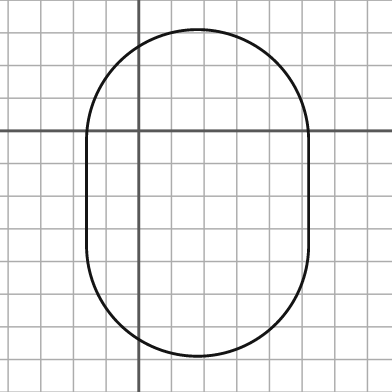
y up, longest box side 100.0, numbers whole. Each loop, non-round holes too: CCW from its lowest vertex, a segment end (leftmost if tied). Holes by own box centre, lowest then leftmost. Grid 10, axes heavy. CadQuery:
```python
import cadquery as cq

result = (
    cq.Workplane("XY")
    .moveTo(-16.0, -35.0)
    .threePointArc((18.0, -69.0), (52.0, -35.0))
    .lineTo(52.0, -3.0)
    .threePointArc((18.0, 31.0), (-16.0, -3.0))
    .close()
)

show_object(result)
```